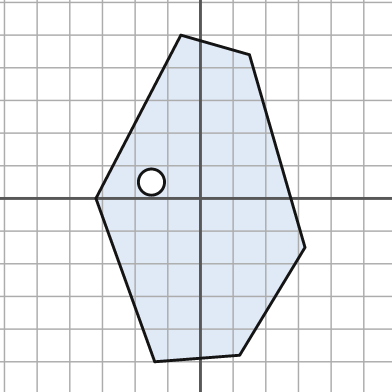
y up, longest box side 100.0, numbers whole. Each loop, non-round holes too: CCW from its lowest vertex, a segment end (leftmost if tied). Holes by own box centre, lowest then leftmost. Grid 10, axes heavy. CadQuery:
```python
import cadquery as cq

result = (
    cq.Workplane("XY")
    .moveTo(-14.0, -50.0)
    .lineTo(12.0, -48.0)
    .lineTo(32.0, -15.0)
    .lineTo(15.0, 44.0)
    .lineTo(-6.0, 50.0)
    .lineTo(-32.0, 0.0)
    .close()
    .moveTo(-15.0, 5.0)
    .circle(4.0)
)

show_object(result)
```